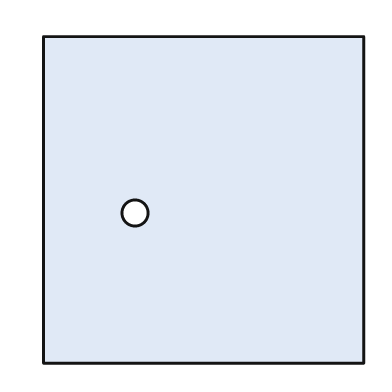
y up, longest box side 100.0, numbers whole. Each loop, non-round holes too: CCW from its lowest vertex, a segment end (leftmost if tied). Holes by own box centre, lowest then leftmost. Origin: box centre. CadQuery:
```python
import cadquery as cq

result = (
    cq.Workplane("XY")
    .moveTo(-49.0, -50.0)
    .lineTo(49.0, -50.0)
    .lineTo(49.0, 50.0)
    .lineTo(-49.0, 50.0)
    .close()
    .moveTo(-21.0, -4.0)
    .circle(4.0)
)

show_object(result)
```